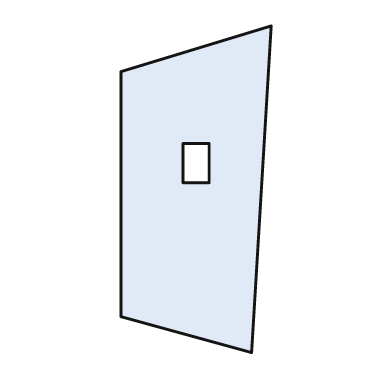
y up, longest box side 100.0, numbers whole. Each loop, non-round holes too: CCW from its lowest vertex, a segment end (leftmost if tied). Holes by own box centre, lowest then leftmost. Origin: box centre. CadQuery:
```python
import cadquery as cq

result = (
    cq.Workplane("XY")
    .moveTo(17.0, -50.0)
    .lineTo(23.0, 50.0)
    .lineTo(-23.0, 36.0)
    .lineTo(-23.0, -39.0)
    .close()
    .moveTo(-4.0, 2.0)
    .lineTo(4.0, 2.0)
    .lineTo(4.0, 14.0)
    .lineTo(-4.0, 14.0)
    .close()
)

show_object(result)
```